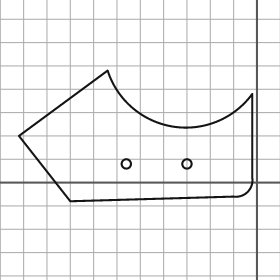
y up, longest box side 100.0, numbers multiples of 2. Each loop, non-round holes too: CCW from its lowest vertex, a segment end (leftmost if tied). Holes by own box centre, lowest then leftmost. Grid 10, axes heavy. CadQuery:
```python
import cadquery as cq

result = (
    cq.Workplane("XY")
    .moveTo(-80.0, -8.0)
    .lineTo(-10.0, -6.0)
    .threePointArc((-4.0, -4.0), (-2.0, 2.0))
    .lineTo(-2.0, 38.0)
    .threePointArc((-36.0, 24.0), (-64.0, 48.0))
    .lineTo(-102.0, 20.0)
    .close()
    .moveTo(-56.0, 8.0)
    .circle(2.0)
    .moveTo(-30.0, 8.0)
    .circle(2.0)
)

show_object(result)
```